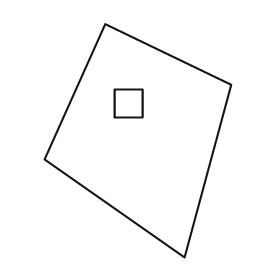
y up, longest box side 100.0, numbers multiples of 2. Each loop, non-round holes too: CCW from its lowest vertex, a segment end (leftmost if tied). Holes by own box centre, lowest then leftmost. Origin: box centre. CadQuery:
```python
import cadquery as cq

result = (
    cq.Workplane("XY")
    .moveTo(20.0, -50.0)
    .lineTo(40.0, 24.0)
    .lineTo(-14.0, 50.0)
    .lineTo(-40.0, -8.0)
    .close()
    .moveTo(-10.0, 10.0)
    .lineTo(2.0, 10.0)
    .lineTo(2.0, 22.0)
    .lineTo(-10.0, 22.0)
    .close()
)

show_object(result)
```